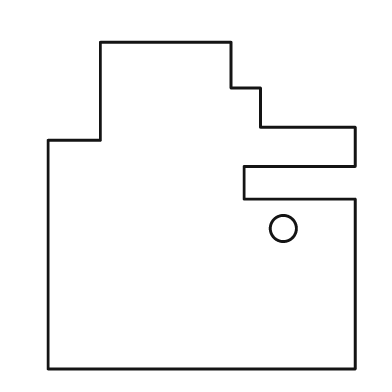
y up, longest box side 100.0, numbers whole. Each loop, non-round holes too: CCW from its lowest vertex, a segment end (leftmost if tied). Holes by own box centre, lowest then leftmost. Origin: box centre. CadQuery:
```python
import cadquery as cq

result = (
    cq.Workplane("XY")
    .moveTo(-47.0, -50.0)
    .lineTo(47.0, -50.0)
    .lineTo(47.0, 2.0)
    .lineTo(13.0, 2.0)
    .lineTo(13.0, 12.0)
    .lineTo(47.0, 12.0)
    .lineTo(47.0, 24.0)
    .lineTo(18.0, 24.0)
    .lineTo(18.0, 36.0)
    .lineTo(9.0, 36.0)
    .lineTo(9.0, 50.0)
    .lineTo(-31.0, 50.0)
    .lineTo(-31.0, 20.0)
    .lineTo(-47.0, 20.0)
    .close()
    .moveTo(25.0, -7.0)
    .circle(4.0)
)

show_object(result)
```